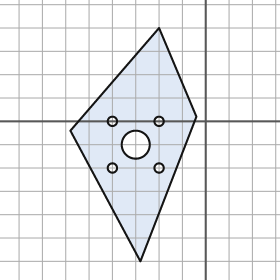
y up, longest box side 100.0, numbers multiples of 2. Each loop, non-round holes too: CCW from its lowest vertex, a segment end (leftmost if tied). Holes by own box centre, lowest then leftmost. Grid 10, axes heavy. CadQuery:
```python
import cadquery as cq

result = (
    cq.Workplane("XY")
    .moveTo(-28.0, -60.0)
    .lineTo(-4.0, 2.0)
    .lineTo(-20.0, 40.0)
    .lineTo(-58.0, -4.0)
    .close()
    .moveTo(-40.0, -20.0)
    .circle(2.0)
    .moveTo(-20.0, -20.0)
    .circle(2.0)
    .moveTo(-30.0, -10.0)
    .circle(6.0)
    .moveTo(-40.0, 0.0)
    .circle(2.0)
    .moveTo(-20.0, 0.0)
    .circle(2.0)
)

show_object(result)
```